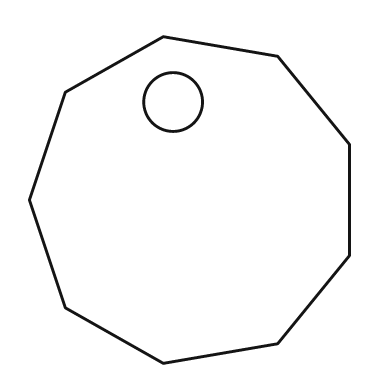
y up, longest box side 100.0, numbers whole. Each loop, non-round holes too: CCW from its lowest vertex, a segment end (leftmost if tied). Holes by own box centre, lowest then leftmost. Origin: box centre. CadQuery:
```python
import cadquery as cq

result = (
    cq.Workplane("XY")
    .moveTo(-8.0, -50.0)
    .lineTo(27.0, -44.0)
    .lineTo(49.0, -17.0)
    .lineTo(49.0, 17.0)
    .lineTo(27.0, 44.0)
    .lineTo(-8.0, 50.0)
    .lineTo(-38.0, 33.0)
    .lineTo(-49.0, 0.0)
    .lineTo(-38.0, -33.0)
    .close()
    .moveTo(-5.0, 30.0)
    .circle(9.0)
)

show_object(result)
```